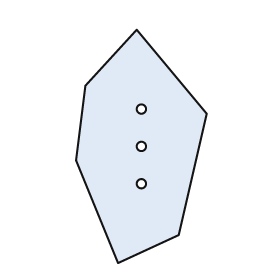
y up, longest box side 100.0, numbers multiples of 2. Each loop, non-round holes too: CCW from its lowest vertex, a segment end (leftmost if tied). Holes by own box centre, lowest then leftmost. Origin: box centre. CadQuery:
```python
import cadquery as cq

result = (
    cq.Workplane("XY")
    .moveTo(-10.0, -50.0)
    .lineTo(16.0, -38.0)
    .lineTo(28.0, 14.0)
    .lineTo(-2.0, 50.0)
    .lineTo(-24.0, 26.0)
    .lineTo(-28.0, -6.0)
    .close()
    .moveTo(0.0, -16.0)
    .circle(2.0)
    .moveTo(0.0, 0.0)
    .circle(2.0)
    .moveTo(0.0, 16.0)
    .circle(2.0)
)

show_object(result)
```